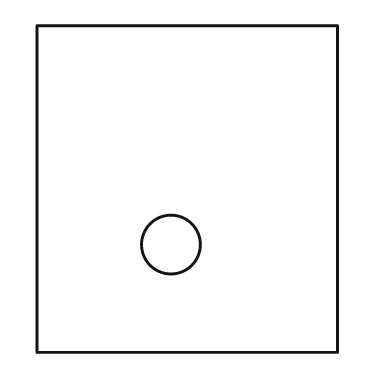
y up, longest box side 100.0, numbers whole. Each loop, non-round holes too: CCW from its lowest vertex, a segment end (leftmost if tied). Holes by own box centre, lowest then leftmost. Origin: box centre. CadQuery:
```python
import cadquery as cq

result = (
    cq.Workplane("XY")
    .moveTo(-46.0, -50.0)
    .lineTo(46.0, -50.0)
    .lineTo(46.0, 50.0)
    .lineTo(-46.0, 50.0)
    .close()
    .moveTo(-5.0, -17.0)
    .circle(9.0)
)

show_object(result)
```